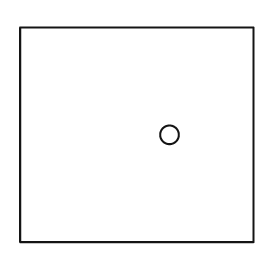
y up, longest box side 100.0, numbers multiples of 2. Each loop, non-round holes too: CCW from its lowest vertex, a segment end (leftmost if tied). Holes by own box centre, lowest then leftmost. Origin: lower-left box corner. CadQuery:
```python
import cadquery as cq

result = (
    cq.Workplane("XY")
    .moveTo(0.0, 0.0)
    .lineTo(100.0, 0.0)
    .lineTo(100.0, 92.0)
    .lineTo(0.0, 92.0)
    .close()
    .moveTo(64.0, 46.0)
    .circle(4.0)
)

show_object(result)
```